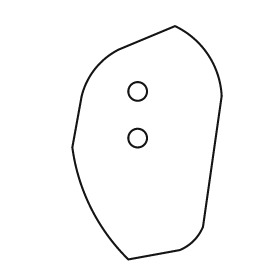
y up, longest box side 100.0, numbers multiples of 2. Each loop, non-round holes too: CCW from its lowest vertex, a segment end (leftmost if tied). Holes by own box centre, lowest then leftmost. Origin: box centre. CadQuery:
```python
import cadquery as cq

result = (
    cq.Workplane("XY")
    .moveTo(-8.0, -50.0)
    .lineTo(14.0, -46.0)
    .threePointArc((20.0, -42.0), (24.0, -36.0))
    .lineTo(32.0, 20.0)
    .threePointArc((26.0, 38.0), (12.0, 50.0))
    .lineTo(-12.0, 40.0)
    .threePointArc((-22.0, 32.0), (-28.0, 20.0))
    .lineTo(-32.0, -2.0)
    .threePointArc((-24.0, -28.0), (-8.0, -50.0))
    .close()
    .moveTo(-4.0, 2.0)
    .circle(4.0)
    .moveTo(-4.0, 22.0)
    .circle(4.0)
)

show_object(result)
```